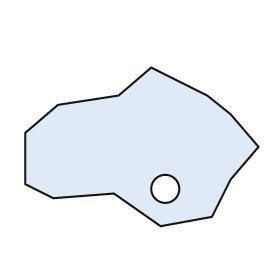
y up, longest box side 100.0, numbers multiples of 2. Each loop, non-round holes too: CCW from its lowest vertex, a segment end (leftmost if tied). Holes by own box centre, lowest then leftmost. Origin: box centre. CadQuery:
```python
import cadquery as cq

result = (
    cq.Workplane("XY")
    .moveTo(8.0, -34.0)
    .lineTo(30.0, -30.0)
    .lineTo(38.0, -14.0)
    .lineTo(50.0, 0.0)
    .lineTo(38.0, 14.0)
    .lineTo(28.0, 22.0)
    .lineTo(4.0, 34.0)
    .lineTo(-10.0, 22.0)
    .lineTo(-36.0, 18.0)
    .lineTo(-50.0, 6.0)
    .lineTo(-50.0, -16.0)
    .lineTo(-38.0, -22.0)
    .lineTo(-12.0, -20.0)
    .close()
    .moveTo(10.0, -18.0)
    .circle(6.0)
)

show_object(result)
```